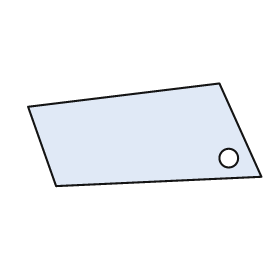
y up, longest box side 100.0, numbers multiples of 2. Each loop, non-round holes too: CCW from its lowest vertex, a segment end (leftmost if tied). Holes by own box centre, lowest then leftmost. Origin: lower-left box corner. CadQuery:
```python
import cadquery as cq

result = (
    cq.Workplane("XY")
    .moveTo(12.0, 0.0)
    .lineTo(100.0, 4.0)
    .lineTo(82.0, 44.0)
    .lineTo(0.0, 34.0)
    .close()
    .moveTo(86.0, 12.0)
    .circle(4.0)
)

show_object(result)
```